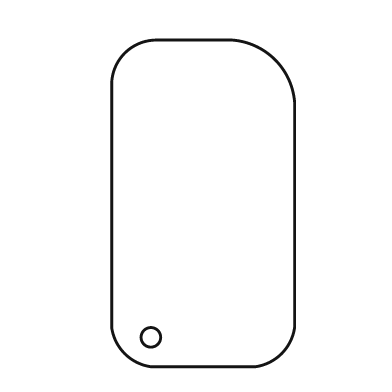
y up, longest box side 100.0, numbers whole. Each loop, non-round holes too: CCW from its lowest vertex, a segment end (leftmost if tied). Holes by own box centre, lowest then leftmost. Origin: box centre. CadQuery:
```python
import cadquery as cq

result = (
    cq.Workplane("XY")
    .moveTo(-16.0, -50.0)
    .lineTo(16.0, -50.0)
    .threePointArc((24.0, -46.0), (28.0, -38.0))
    .lineTo(28.0, 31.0)
    .threePointArc((22.0, 44.0), (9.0, 50.0))
    .lineTo(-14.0, 50.0)
    .threePointArc((-24.0, 46.0), (-28.0, 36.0))
    .lineTo(-28.0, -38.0)
    .threePointArc((-24.0, -46.0), (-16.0, -50.0))
    .close()
    .moveTo(-16.0, -41.0)
    .circle(3.0)
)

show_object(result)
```